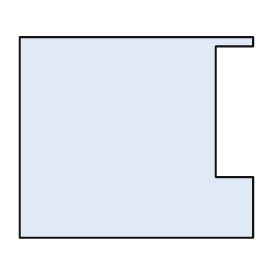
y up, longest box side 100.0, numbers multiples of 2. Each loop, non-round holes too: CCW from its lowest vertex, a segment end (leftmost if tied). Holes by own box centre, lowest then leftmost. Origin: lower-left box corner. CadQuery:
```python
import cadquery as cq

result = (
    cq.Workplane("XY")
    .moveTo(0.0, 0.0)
    .lineTo(100.0, 0.0)
    .lineTo(100.0, 26.0)
    .lineTo(84.0, 26.0)
    .lineTo(84.0, 82.0)
    .lineTo(100.0, 82.0)
    .lineTo(100.0, 86.0)
    .lineTo(0.0, 86.0)
    .close()
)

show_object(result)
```